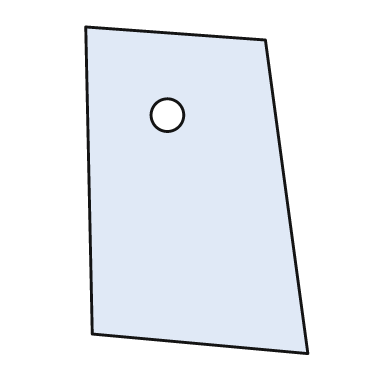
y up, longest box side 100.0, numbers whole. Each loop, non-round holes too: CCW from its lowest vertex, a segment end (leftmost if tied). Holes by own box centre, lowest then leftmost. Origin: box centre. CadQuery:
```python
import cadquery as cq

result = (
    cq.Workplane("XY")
    .moveTo(34.0, -50.0)
    .lineTo(21.0, 46.0)
    .lineTo(-34.0, 50.0)
    .lineTo(-32.0, -44.0)
    .close()
    .moveTo(-9.0, 23.0)
    .circle(5.0)
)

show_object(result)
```